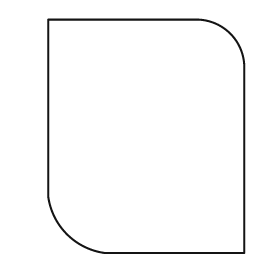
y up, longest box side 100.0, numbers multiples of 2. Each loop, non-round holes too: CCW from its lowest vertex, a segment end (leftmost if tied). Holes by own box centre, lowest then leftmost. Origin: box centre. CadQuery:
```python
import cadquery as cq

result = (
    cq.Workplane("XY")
    .moveTo(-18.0, -50.0)
    .lineTo(42.0, -50.0)
    .lineTo(42.0, 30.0)
    .threePointArc((36.0, 44.0), (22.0, 50.0))
    .lineTo(-42.0, 50.0)
    .lineTo(-42.0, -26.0)
    .threePointArc((-34.0, -42.0), (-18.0, -50.0))
    .close()
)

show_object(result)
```